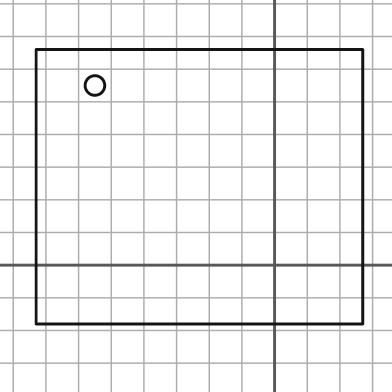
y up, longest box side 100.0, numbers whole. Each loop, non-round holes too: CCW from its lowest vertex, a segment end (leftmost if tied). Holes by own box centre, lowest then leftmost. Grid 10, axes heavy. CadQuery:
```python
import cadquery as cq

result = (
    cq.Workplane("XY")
    .moveTo(-73.0, -18.0)
    .lineTo(27.0, -18.0)
    .lineTo(27.0, 66.0)
    .lineTo(-73.0, 66.0)
    .close()
    .moveTo(-55.0, 55.0)
    .circle(3.0)
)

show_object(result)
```